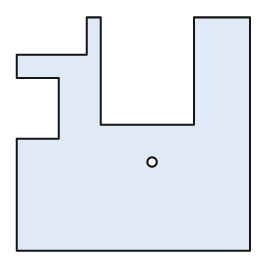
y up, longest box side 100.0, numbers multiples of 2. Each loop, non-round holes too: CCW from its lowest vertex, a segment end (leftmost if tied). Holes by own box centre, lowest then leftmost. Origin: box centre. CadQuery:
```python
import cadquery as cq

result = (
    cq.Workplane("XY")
    .moveTo(-50.0, -50.0)
    .lineTo(50.0, -50.0)
    .lineTo(50.0, 50.0)
    .lineTo(26.0, 50.0)
    .lineTo(26.0, 4.0)
    .lineTo(-14.0, 4.0)
    .lineTo(-14.0, 50.0)
    .lineTo(-20.0, 50.0)
    .lineTo(-20.0, 34.0)
    .lineTo(-50.0, 34.0)
    .lineTo(-50.0, 24.0)
    .lineTo(-32.0, 24.0)
    .lineTo(-32.0, -2.0)
    .lineTo(-50.0, -2.0)
    .close()
    .moveTo(8.0, -12.0)
    .circle(2.0)
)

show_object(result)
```